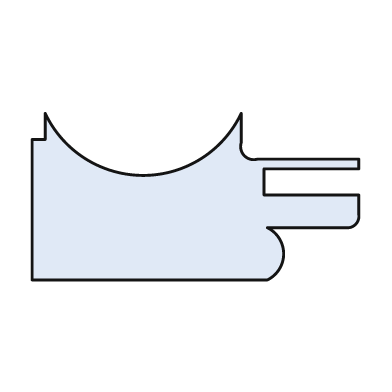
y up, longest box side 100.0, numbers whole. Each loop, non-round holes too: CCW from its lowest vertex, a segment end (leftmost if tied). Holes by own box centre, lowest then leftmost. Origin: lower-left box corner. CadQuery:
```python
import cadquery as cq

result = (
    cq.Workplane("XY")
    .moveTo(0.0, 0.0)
    .lineTo(72.0, 0.0)
    .threePointArc((77.0, 8.0), (72.0, 16.0))
    .lineTo(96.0, 16.0)
    .threePointArc((99.0, 17.0), (100.0, 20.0))
    .lineTo(100.0, 26.0)
    .lineTo(71.0, 26.0)
    .lineTo(71.0, 34.0)
    .lineTo(100.0, 34.0)
    .lineTo(100.0, 37.0)
    .lineTo(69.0, 37.0)
    .threePointArc((65.0, 38.0), (64.0, 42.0))
    .lineTo(64.0, 51.0)
    .threePointArc((34.0, 32.0), (4.0, 51.0))
    .lineTo(4.0, 43.0)
    .lineTo(0.0, 43.0)
    .close()
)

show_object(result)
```